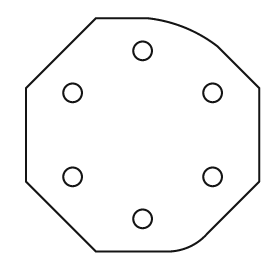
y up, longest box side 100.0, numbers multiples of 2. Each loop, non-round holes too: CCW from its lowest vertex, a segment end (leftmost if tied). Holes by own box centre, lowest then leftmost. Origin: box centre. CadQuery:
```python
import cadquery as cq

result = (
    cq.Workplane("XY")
    .moveTo(-20.0, -50.0)
    .lineTo(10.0, -50.0)
    .threePointArc((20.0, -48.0), (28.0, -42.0))
    .lineTo(50.0, -20.0)
    .lineTo(50.0, 20.0)
    .lineTo(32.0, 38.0)
    .threePointArc((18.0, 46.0), (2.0, 50.0))
    .lineTo(-20.0, 50.0)
    .lineTo(-50.0, 20.0)
    .lineTo(-50.0, -20.0)
    .close()
    .moveTo(0.0, -36.0)
    .circle(4.0)
    .moveTo(-30.0, -18.0)
    .circle(4.0)
    .moveTo(30.0, -18.0)
    .circle(4.0)
    .moveTo(-30.0, 18.0)
    .circle(4.0)
    .moveTo(30.0, 18.0)
    .circle(4.0)
    .moveTo(0.0, 36.0)
    .circle(4.0)
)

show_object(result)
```